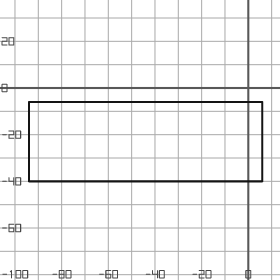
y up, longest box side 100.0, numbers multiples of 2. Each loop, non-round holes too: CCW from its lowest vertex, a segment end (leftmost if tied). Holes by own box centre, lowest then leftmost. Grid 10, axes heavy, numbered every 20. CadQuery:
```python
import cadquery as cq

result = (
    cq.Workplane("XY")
    .moveTo(-94.0, -40.0)
    .lineTo(6.0, -40.0)
    .lineTo(6.0, -6.0)
    .lineTo(-94.0, -6.0)
    .close()
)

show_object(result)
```